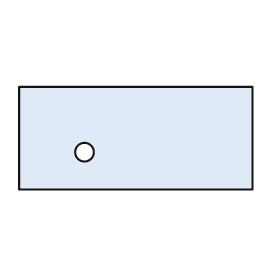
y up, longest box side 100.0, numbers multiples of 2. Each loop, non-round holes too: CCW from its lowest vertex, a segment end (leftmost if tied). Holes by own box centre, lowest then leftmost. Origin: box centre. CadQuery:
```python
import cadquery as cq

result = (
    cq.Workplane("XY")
    .moveTo(-50.0, -22.0)
    .lineTo(50.0, -22.0)
    .lineTo(50.0, 22.0)
    .lineTo(-50.0, 22.0)
    .close()
    .moveTo(-22.0, -6.0)
    .circle(4.0)
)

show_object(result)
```